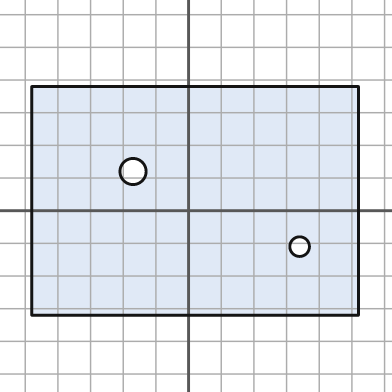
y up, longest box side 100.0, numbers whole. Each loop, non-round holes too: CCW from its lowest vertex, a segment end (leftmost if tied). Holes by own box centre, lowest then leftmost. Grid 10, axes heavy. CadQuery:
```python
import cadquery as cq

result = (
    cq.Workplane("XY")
    .moveTo(-48.0, -32.0)
    .lineTo(52.0, -32.0)
    .lineTo(52.0, 38.0)
    .lineTo(-48.0, 38.0)
    .close()
    .moveTo(34.0, -11.0)
    .circle(3.0)
    .moveTo(-17.0, 12.0)
    .circle(4.0)
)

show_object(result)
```